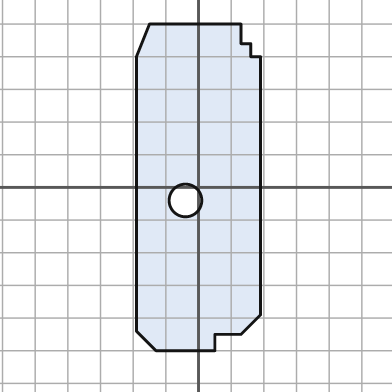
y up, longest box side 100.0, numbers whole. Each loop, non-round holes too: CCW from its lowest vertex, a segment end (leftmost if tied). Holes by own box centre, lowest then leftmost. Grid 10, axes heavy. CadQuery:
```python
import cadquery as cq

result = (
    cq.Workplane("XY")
    .moveTo(-13.0, -50.0)
    .lineTo(5.0, -50.0)
    .lineTo(5.0, -45.0)
    .lineTo(13.0, -45.0)
    .lineTo(19.0, -39.0)
    .lineTo(19.0, 40.0)
    .lineTo(16.0, 40.0)
    .lineTo(16.0, 44.0)
    .lineTo(13.0, 44.0)
    .lineTo(13.0, 50.0)
    .lineTo(-15.0, 50.0)
    .lineTo(-19.0, 40.0)
    .lineTo(-19.0, -44.0)
    .close()
    .moveTo(-4.0, -4.0)
    .circle(5.0)
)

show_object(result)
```